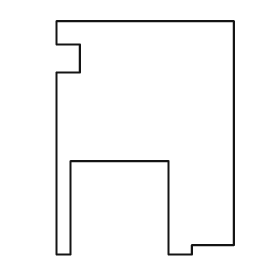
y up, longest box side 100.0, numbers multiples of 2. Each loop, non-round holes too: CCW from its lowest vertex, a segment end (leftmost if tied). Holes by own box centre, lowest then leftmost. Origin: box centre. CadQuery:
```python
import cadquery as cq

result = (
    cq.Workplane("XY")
    .moveTo(-38.0, -50.0)
    .lineTo(-32.0, -50.0)
    .lineTo(-32.0, -10.0)
    .lineTo(10.0, -10.0)
    .lineTo(10.0, -50.0)
    .lineTo(20.0, -50.0)
    .lineTo(20.0, -46.0)
    .lineTo(38.0, -46.0)
    .lineTo(38.0, 50.0)
    .lineTo(-38.0, 50.0)
    .lineTo(-38.0, 40.0)
    .lineTo(-28.0, 40.0)
    .lineTo(-28.0, 28.0)
    .lineTo(-38.0, 28.0)
    .close()
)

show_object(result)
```